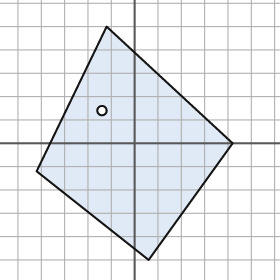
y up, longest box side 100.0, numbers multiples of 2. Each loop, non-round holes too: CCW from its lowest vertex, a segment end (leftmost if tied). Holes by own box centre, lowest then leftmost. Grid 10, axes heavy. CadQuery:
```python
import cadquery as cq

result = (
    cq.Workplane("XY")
    .moveTo(6.0, -50.0)
    .lineTo(42.0, 0.0)
    .lineTo(-12.0, 50.0)
    .lineTo(-42.0, -12.0)
    .close()
    .moveTo(-14.0, 14.0)
    .circle(2.0)
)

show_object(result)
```